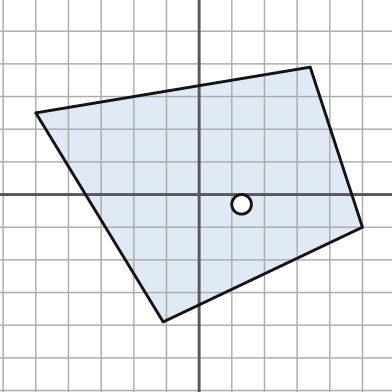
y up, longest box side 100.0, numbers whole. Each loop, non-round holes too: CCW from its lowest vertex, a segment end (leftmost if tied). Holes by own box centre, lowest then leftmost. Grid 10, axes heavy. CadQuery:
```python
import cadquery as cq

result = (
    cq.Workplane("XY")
    .moveTo(-11.0, -39.0)
    .lineTo(50.0, -10.0)
    .lineTo(34.0, 39.0)
    .lineTo(-50.0, 25.0)
    .close()
    .moveTo(13.0, -3.0)
    .circle(3.0)
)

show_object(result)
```